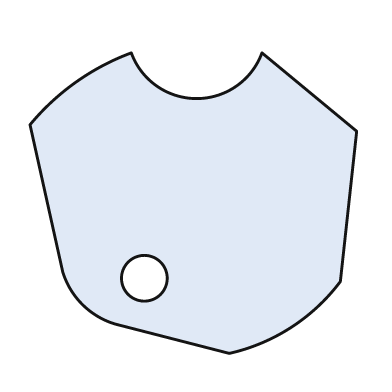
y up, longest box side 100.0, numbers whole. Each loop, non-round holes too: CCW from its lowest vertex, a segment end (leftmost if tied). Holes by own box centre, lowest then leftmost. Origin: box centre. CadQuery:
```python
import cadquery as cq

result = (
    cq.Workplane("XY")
    .moveTo(11.0, -46.0)
    .threePointArc((30.0, -38.0), (45.0, -24.0))
    .lineTo(50.0, 22.0)
    .lineTo(21.0, 46.0)
    .threePointArc((1.0, 32.0), (-19.0, 46.0))
    .threePointArc((-36.0, 37.0), (-50.0, 24.0))
    .lineTo(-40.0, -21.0)
    .threePointArc((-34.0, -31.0), (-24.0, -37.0))
    .close()
    .moveTo(-15.0, -23.0)
    .circle(7.0)
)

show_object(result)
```